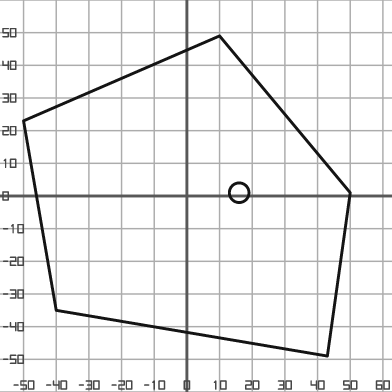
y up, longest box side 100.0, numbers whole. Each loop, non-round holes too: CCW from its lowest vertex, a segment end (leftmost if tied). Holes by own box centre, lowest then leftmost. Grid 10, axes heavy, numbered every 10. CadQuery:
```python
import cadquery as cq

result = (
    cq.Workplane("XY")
    .moveTo(43.0, -49.0)
    .lineTo(50.0, 1.0)
    .lineTo(10.0, 49.0)
    .lineTo(-50.0, 23.0)
    .lineTo(-40.0, -35.0)
    .close()
    .moveTo(16.0, 1.0)
    .circle(3.0)
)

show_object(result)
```